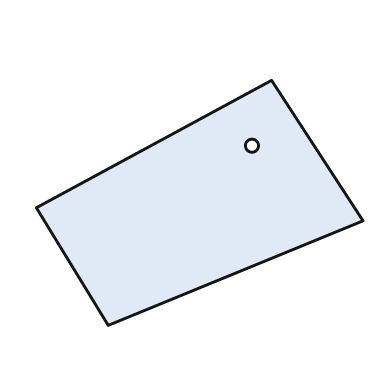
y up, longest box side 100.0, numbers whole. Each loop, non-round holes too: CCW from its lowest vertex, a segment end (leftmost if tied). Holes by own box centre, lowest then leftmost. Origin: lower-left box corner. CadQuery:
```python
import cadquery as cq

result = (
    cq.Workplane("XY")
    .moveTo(22.0, 0.0)
    .lineTo(100.0, 32.0)
    .lineTo(72.0, 75.0)
    .lineTo(0.0, 36.0)
    .close()
    .moveTo(66.0, 55.0)
    .circle(2.0)
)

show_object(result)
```